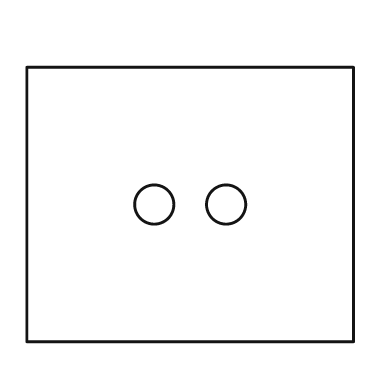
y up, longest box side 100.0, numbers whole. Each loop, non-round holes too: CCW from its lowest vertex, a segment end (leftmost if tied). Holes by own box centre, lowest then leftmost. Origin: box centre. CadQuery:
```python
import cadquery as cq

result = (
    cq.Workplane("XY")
    .moveTo(-50.0, -42.0)
    .lineTo(50.0, -42.0)
    .lineTo(50.0, 42.0)
    .lineTo(-50.0, 42.0)
    .close()
    .moveTo(-11.0, 0.0)
    .circle(6.0)
    .moveTo(11.0, 0.0)
    .circle(6.0)
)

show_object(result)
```